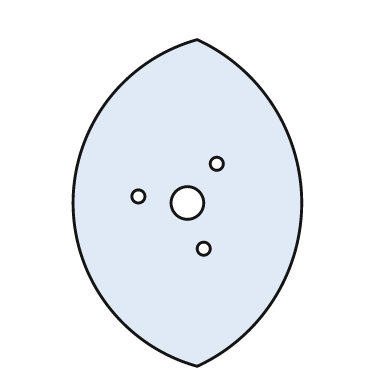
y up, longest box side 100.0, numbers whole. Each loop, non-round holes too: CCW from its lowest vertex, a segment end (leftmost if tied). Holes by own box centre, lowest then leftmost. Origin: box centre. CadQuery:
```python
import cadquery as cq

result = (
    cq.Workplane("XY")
    .moveTo(3.0, -50.0)
    .threePointArc((35.0, 0.0), (3.0, 50.0))
    .threePointArc((-35.0, 0.0), (3.0, -50.0))
    .close()
    .moveTo(5.0, -14.0)
    .circle(2.0)
    .moveTo(0.0, 0.0)
    .circle(5.0)
    .moveTo(-15.0, 2.0)
    .circle(2.0)
    .moveTo(9.0, 12.0)
    .circle(2.0)
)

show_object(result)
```